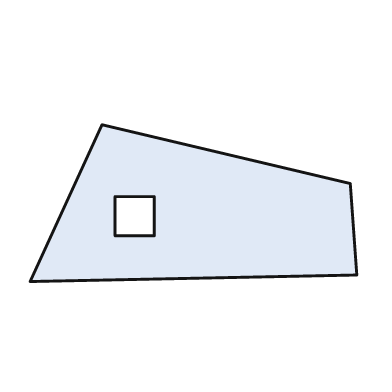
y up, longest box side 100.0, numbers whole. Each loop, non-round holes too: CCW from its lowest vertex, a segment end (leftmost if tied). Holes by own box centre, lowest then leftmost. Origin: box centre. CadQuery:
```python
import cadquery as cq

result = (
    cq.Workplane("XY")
    .moveTo(-50.0, -24.0)
    .lineTo(50.0, -22.0)
    .lineTo(48.0, 6.0)
    .lineTo(-28.0, 24.0)
    .close()
    .moveTo(-24.0, -10.0)
    .lineTo(-12.0, -10.0)
    .lineTo(-12.0, 2.0)
    .lineTo(-24.0, 2.0)
    .close()
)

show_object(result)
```